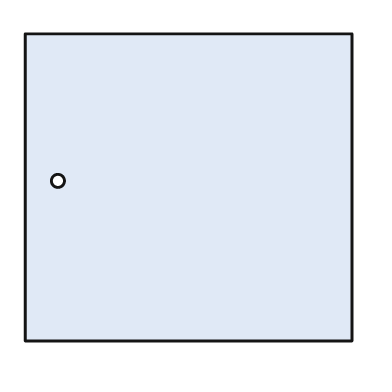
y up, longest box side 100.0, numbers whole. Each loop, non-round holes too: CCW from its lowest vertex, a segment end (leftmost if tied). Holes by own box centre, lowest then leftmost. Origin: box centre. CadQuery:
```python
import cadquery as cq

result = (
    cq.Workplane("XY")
    .moveTo(-50.0, -47.0)
    .lineTo(50.0, -47.0)
    .lineTo(50.0, 47.0)
    .lineTo(-50.0, 47.0)
    .close()
    .moveTo(-40.0, 2.0)
    .circle(2.0)
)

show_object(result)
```